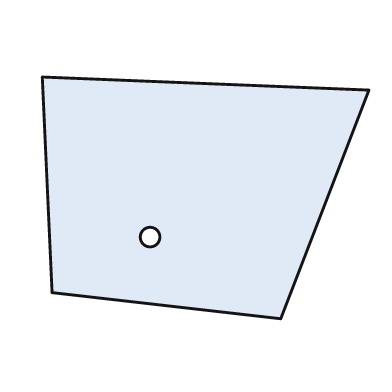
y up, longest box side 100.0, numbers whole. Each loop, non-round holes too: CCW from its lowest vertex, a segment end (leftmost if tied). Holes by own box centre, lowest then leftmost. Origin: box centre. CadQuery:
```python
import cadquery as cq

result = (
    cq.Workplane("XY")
    .moveTo(23.0, -37.0)
    .lineTo(50.0, 33.0)
    .lineTo(-50.0, 37.0)
    .lineTo(-47.0, -29.0)
    .close()
    .moveTo(-17.0, -12.0)
    .circle(3.0)
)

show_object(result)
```